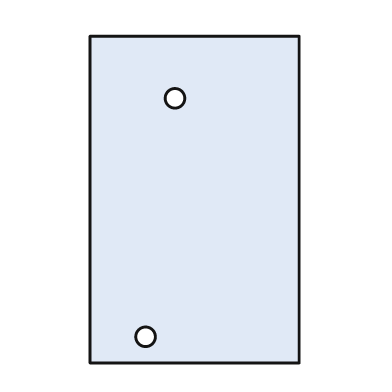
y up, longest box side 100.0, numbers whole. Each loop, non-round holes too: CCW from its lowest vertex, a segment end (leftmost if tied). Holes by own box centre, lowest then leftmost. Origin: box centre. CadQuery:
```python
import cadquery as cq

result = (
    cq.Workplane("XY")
    .moveTo(-32.0, -50.0)
    .lineTo(32.0, -50.0)
    .lineTo(32.0, 50.0)
    .lineTo(-32.0, 50.0)
    .close()
    .moveTo(-15.0, -42.0)
    .circle(3.0)
    .moveTo(-6.0, 31.0)
    .circle(3.0)
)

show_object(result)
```